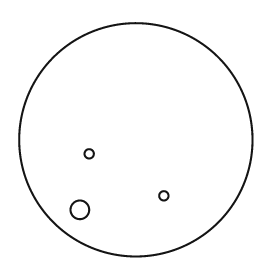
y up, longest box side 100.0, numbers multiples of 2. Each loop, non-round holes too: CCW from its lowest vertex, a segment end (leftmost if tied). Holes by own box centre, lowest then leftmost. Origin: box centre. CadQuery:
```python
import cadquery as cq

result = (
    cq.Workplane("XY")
    .moveTo(0.0, 0.0)
    .circle(50.0)
    .moveTo(-24.0, -30.0)
    .circle(4.0)
    .moveTo(12.0, -24.0)
    .circle(2.0)
    .moveTo(-20.0, -6.0)
    .circle(2.0)
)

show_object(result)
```